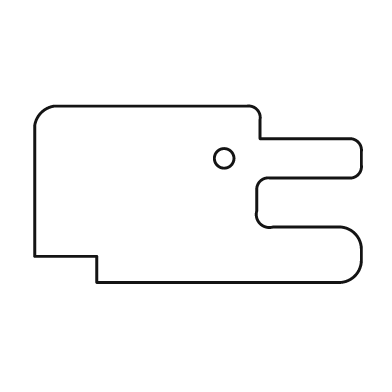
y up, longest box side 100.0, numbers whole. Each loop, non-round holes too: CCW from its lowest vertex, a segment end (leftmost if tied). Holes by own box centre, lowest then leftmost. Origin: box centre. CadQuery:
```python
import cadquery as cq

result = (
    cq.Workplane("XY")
    .moveTo(-31.0, -27.0)
    .lineTo(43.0, -27.0)
    .threePointArc((48.0, -25.0), (50.0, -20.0))
    .lineTo(50.0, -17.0)
    .threePointArc((48.0, -12.0), (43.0, -10.0))
    .lineTo(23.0, -10.0)
    .threePointArc((19.0, -9.0), (18.0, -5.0))
    .lineTo(18.0, 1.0)
    .threePointArc((19.0, 4.0), (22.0, 5.0))
    .lineTo(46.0, 5.0)
    .threePointArc((49.0, 6.0), (50.0, 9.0))
    .lineTo(50.0, 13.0)
    .threePointArc((49.0, 16.0), (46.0, 17.0))
    .lineTo(19.0, 17.0)
    .lineTo(19.0, 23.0)
    .threePointArc((18.0, 26.0), (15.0, 27.0))
    .lineTo(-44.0, 27.0)
    .threePointArc((-48.0, 25.0), (-50.0, 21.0))
    .lineTo(-50.0, -19.0)
    .lineTo(-31.0, -19.0)
    .close()
    .moveTo(8.0, 11.0)
    .circle(3.0)
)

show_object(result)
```